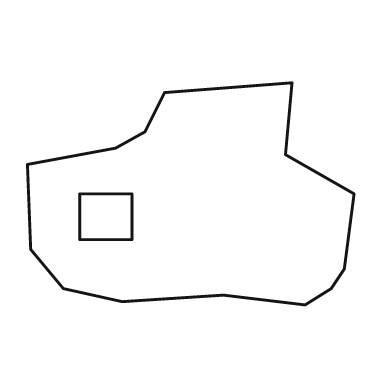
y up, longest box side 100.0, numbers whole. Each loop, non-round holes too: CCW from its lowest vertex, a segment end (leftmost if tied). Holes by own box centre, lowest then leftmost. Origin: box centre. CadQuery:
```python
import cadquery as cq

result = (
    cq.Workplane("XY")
    .moveTo(35.0, -34.0)
    .lineTo(43.0, -29.0)
    .lineTo(47.0, -23.0)
    .lineTo(50.0, 0.0)
    .lineTo(29.0, 12.0)
    .lineTo(31.0, 34.0)
    .lineTo(-8.0, 31.0)
    .lineTo(-14.0, 19.0)
    .lineTo(-23.0, 14.0)
    .lineTo(-50.0, 9.0)
    .lineTo(-49.0, -17.0)
    .lineTo(-39.0, -29.0)
    .lineTo(-21.0, -33.0)
    .lineTo(10.0, -31.0)
    .close()
    .moveTo(-34.0, -14.0)
    .lineTo(-18.0, -14.0)
    .lineTo(-18.0, 0.0)
    .lineTo(-34.0, 0.0)
    .close()
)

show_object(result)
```